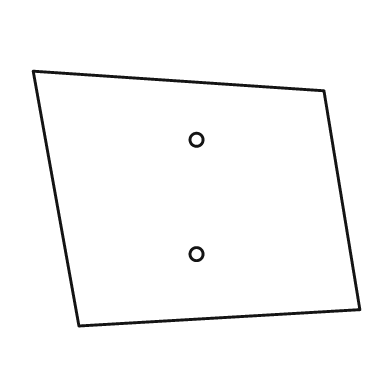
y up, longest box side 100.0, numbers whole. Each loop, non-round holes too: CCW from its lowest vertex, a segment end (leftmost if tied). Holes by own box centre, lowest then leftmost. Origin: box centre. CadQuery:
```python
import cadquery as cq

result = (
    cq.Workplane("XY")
    .moveTo(-36.0, -39.0)
    .lineTo(50.0, -34.0)
    .lineTo(39.0, 33.0)
    .lineTo(-50.0, 39.0)
    .close()
    .moveTo(0.0, -17.0)
    .circle(2.0)
    .moveTo(0.0, 18.0)
    .circle(2.0)
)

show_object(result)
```